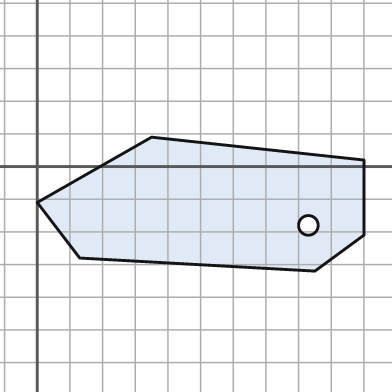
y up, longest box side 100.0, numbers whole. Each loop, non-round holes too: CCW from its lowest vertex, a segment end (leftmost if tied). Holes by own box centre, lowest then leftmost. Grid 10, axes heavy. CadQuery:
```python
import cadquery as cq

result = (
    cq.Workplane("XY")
    .moveTo(85.0, -32.0)
    .lineTo(100.0, -21.0)
    .lineTo(100.0, 2.0)
    .lineTo(35.0, 9.0)
    .lineTo(0.0, -11.0)
    .lineTo(13.0, -28.0)
    .close()
    .moveTo(83.0, -18.0)
    .circle(3.0)
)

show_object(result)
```